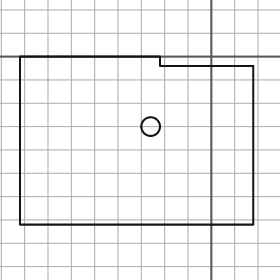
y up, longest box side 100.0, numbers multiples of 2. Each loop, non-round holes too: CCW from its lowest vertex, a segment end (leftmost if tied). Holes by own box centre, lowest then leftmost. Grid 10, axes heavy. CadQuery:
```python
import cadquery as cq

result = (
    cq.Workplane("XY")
    .moveTo(-82.0, -72.0)
    .lineTo(18.0, -72.0)
    .lineTo(18.0, -4.0)
    .lineTo(-22.0, -4.0)
    .lineTo(-22.0, 0.0)
    .lineTo(-82.0, 0.0)
    .close()
    .moveTo(-26.0, -30.0)
    .circle(4.0)
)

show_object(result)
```